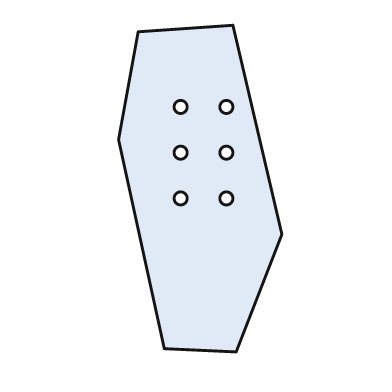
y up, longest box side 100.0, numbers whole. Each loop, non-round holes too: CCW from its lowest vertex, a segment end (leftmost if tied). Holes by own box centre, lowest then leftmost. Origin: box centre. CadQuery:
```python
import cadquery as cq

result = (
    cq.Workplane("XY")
    .moveTo(11.0, -50.0)
    .lineTo(25.0, -14.0)
    .lineTo(10.0, 50.0)
    .lineTo(-19.0, 48.0)
    .lineTo(-25.0, 15.0)
    .lineTo(-11.0, -49.0)
    .close()
    .moveTo(-6.0, -3.0)
    .circle(2.0)
    .moveTo(8.0, -3.0)
    .circle(2.0)
    .moveTo(-6.0, 11.0)
    .circle(2.0)
    .moveTo(8.0, 11.0)
    .circle(2.0)
    .moveTo(-6.0, 25.0)
    .circle(2.0)
    .moveTo(8.0, 25.0)
    .circle(2.0)
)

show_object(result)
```